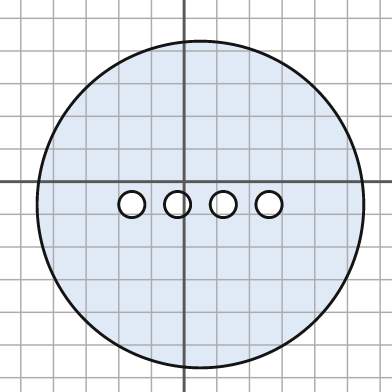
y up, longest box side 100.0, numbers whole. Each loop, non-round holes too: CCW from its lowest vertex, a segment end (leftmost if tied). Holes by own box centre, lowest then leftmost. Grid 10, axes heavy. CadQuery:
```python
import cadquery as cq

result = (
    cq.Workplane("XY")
    .moveTo(5.0, -7.0)
    .circle(50.0)
    .moveTo(-16.0, -7.0)
    .circle(4.0)
    .moveTo(-2.0, -7.0)
    .circle(4.0)
    .moveTo(12.0, -7.0)
    .circle(4.0)
    .moveTo(26.0, -7.0)
    .circle(4.0)
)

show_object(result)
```